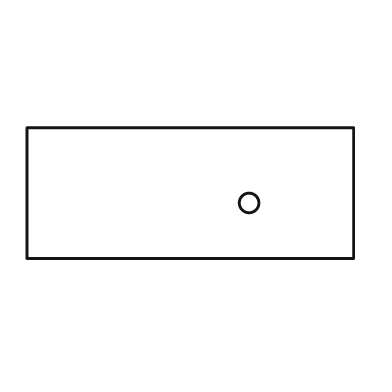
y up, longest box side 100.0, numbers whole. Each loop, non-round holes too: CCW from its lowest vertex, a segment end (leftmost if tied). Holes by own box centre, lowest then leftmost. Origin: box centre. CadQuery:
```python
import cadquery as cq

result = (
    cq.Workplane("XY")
    .moveTo(-50.0, -20.0)
    .lineTo(50.0, -20.0)
    .lineTo(50.0, 20.0)
    .lineTo(-50.0, 20.0)
    .close()
    .moveTo(18.0, -3.0)
    .circle(3.0)
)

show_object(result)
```